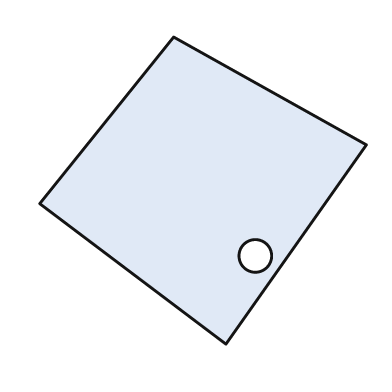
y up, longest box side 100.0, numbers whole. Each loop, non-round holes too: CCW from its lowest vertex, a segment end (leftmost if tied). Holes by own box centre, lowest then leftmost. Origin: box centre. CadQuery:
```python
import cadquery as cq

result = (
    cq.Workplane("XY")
    .moveTo(7.0, -47.0)
    .lineTo(50.0, 14.0)
    .lineTo(-9.0, 47.0)
    .lineTo(-50.0, -4.0)
    .close()
    .moveTo(16.0, -20.0)
    .circle(5.0)
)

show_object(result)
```